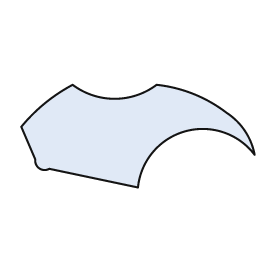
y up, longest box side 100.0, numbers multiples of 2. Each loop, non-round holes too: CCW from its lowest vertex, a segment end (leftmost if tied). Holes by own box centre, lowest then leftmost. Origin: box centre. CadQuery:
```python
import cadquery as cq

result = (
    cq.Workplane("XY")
    .moveTo(0.0, -22.0)
    .threePointArc((20.0, 2.0), (50.0, -8.0))
    .threePointArc((46.0, 2.0), (38.0, 10.0))
    .threePointArc((24.0, 18.0), (8.0, 22.0))
    .threePointArc((-10.0, 16.0), (-28.0, 22.0))
    .threePointArc((-40.0, 14.0), (-50.0, 4.0))
    .lineTo(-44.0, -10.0)
    .threePointArc((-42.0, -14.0), (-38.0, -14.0))
    .close()
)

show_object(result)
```